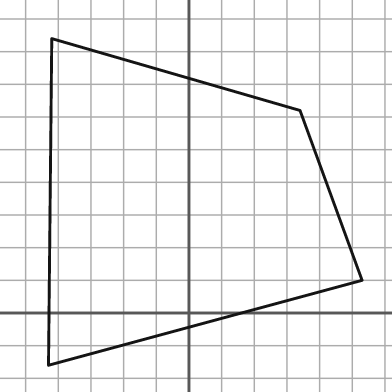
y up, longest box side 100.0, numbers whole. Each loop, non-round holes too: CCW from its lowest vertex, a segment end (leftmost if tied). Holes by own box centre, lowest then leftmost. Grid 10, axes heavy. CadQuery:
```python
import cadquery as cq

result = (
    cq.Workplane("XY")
    .moveTo(-43.0, -16.0)
    .lineTo(53.0, 10.0)
    .lineTo(34.0, 62.0)
    .lineTo(-42.0, 84.0)
    .close()
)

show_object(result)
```